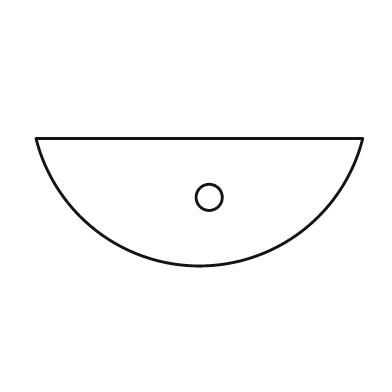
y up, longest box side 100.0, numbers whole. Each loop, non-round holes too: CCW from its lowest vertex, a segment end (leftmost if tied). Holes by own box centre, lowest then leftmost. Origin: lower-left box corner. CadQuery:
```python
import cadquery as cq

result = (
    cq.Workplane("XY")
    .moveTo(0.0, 39.0)
    .threePointArc((50.0, 0.0), (100.0, 39.0))
    .close()
    .moveTo(53.0, 21.0)
    .circle(4.0)
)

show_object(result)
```